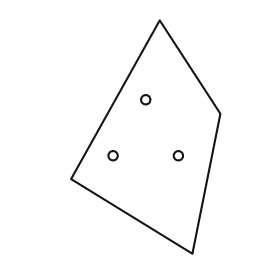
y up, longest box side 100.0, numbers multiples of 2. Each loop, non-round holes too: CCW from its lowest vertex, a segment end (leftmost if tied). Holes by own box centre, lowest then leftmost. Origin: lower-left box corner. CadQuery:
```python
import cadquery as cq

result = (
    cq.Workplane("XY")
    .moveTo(52.0, 0.0)
    .lineTo(64.0, 60.0)
    .lineTo(38.0, 100.0)
    .lineTo(0.0, 32.0)
    .close()
    .moveTo(18.0, 42.0)
    .circle(2.0)
    .moveTo(46.0, 42.0)
    .circle(2.0)
    .moveTo(32.0, 66.0)
    .circle(2.0)
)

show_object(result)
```